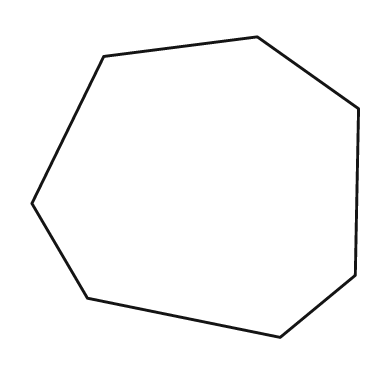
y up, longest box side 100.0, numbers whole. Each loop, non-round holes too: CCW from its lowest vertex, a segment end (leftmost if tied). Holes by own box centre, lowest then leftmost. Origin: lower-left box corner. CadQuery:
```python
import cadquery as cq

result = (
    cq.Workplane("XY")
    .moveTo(76.0, 0.0)
    .lineTo(99.0, 19.0)
    .lineTo(100.0, 70.0)
    .lineTo(69.0, 92.0)
    .lineTo(22.0, 86.0)
    .lineTo(0.0, 41.0)
    .lineTo(17.0, 12.0)
    .close()
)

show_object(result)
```